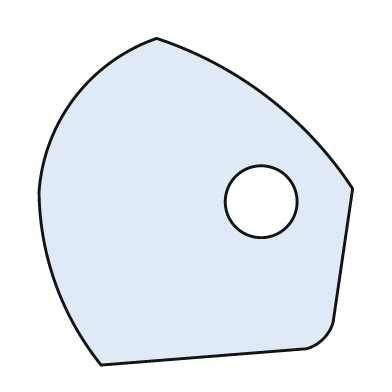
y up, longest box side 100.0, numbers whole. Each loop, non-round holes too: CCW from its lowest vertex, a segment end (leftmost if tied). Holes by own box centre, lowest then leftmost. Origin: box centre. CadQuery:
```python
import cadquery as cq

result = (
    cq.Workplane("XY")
    .moveTo(-29.0, -50.0)
    .lineTo(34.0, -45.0)
    .threePointArc((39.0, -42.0), (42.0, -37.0))
    .lineTo(48.0, 4.0)
    .threePointArc((22.0, 32.0), (-12.0, 50.0))
    .threePointArc((-37.0, 32.0), (-48.0, 3.0))
    .threePointArc((-43.0, -25.0), (-29.0, -50.0))
    .close()
    .moveTo(20.0, 0.0)
    .circle(11.0)
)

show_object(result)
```